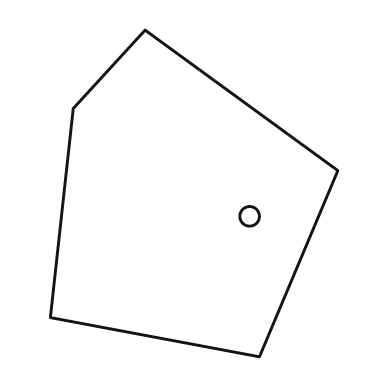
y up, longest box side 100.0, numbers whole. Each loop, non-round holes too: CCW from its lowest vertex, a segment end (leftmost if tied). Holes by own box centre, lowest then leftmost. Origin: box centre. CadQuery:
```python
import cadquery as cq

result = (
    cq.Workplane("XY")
    .moveTo(20.0, -50.0)
    .lineTo(44.0, 7.0)
    .lineTo(-15.0, 50.0)
    .lineTo(-37.0, 26.0)
    .lineTo(-44.0, -38.0)
    .close()
    .moveTo(17.0, -7.0)
    .circle(3.0)
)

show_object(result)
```